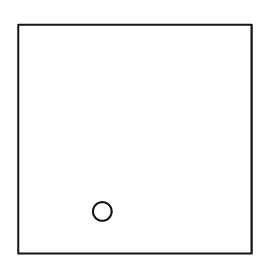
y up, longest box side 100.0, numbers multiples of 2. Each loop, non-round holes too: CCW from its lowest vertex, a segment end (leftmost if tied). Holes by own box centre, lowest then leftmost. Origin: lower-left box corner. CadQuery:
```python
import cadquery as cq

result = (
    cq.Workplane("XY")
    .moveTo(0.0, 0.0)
    .lineTo(100.0, 0.0)
    .lineTo(100.0, 98.0)
    .lineTo(0.0, 98.0)
    .close()
    .moveTo(36.0, 18.0)
    .circle(4.0)
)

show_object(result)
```